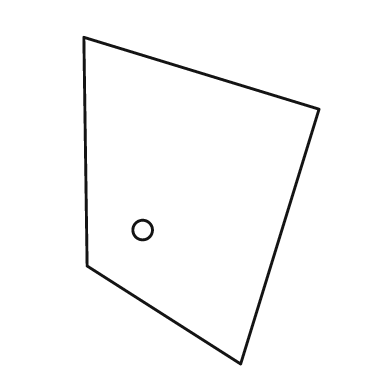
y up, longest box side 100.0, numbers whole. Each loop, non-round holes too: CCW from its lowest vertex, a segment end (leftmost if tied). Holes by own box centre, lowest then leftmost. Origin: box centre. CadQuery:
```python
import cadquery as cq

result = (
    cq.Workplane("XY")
    .moveTo(12.0, -50.0)
    .lineTo(36.0, 28.0)
    .lineTo(-36.0, 50.0)
    .lineTo(-35.0, -20.0)
    .close()
    .moveTo(-18.0, -9.0)
    .circle(3.0)
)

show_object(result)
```